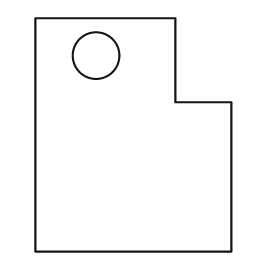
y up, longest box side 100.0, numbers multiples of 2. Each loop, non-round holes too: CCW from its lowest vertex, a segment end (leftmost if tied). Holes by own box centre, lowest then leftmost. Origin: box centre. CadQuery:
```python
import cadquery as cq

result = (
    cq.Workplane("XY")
    .moveTo(-42.0, -50.0)
    .lineTo(42.0, -50.0)
    .lineTo(42.0, 14.0)
    .lineTo(18.0, 14.0)
    .lineTo(18.0, 50.0)
    .lineTo(-42.0, 50.0)
    .close()
    .moveTo(-16.0, 34.0)
    .circle(10.0)
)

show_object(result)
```